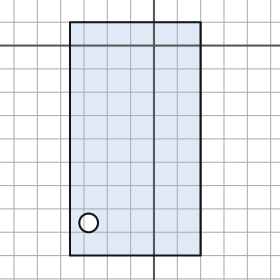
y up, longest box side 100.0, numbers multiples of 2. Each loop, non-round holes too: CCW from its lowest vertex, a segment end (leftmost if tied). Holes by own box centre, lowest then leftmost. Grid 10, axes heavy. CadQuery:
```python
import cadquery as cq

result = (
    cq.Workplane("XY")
    .moveTo(-36.0, -90.0)
    .lineTo(20.0, -90.0)
    .lineTo(20.0, 10.0)
    .lineTo(-36.0, 10.0)
    .close()
    .moveTo(-28.0, -76.0)
    .circle(4.0)
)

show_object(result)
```